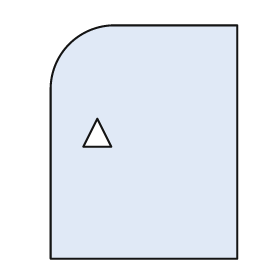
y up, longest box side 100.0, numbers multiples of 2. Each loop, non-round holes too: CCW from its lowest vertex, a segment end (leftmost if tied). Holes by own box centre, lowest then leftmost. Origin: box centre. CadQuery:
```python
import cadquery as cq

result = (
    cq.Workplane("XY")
    .moveTo(-40.0, -50.0)
    .lineTo(40.0, -50.0)
    .lineTo(40.0, 50.0)
    .lineTo(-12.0, 50.0)
    .threePointArc((-32.0, 42.0), (-40.0, 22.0))
    .close()
    .moveTo(-26.0, -2.0)
    .lineTo(-14.0, -2.0)
    .lineTo(-20.0, 10.0)
    .close()
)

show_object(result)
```